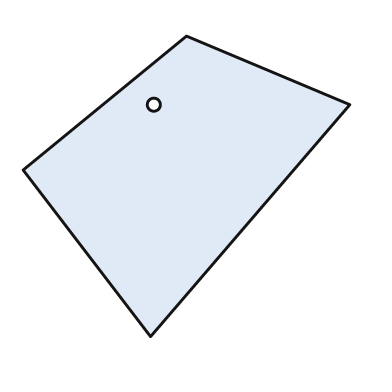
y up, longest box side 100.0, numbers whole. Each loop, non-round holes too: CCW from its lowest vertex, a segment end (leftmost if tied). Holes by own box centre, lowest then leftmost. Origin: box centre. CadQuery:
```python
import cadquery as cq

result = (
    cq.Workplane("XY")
    .moveTo(-11.0, -46.0)
    .lineTo(50.0, 25.0)
    .lineTo(0.0, 46.0)
    .lineTo(-50.0, 5.0)
    .close()
    .moveTo(-10.0, 25.0)
    .circle(2.0)
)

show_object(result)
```